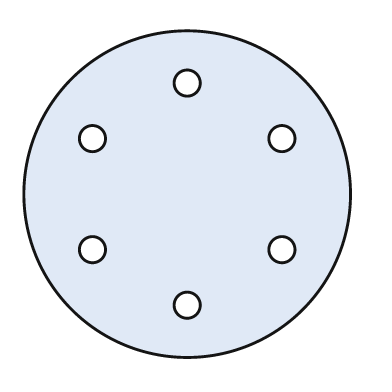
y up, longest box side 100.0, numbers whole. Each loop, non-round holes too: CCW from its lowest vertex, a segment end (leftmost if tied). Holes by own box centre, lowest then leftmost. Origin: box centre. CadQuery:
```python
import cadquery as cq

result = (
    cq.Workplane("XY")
    .moveTo(0.0, 0.0)
    .circle(50.0)
    .moveTo(0.0, -34.0)
    .circle(4.0)
    .moveTo(-29.0, -17.0)
    .circle(4.0)
    .moveTo(29.0, -17.0)
    .circle(4.0)
    .moveTo(-29.0, 17.0)
    .circle(4.0)
    .moveTo(29.0, 17.0)
    .circle(4.0)
    .moveTo(0.0, 34.0)
    .circle(4.0)
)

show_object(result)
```